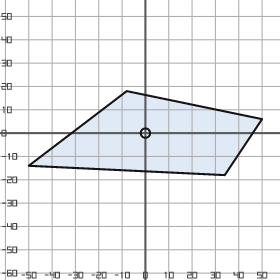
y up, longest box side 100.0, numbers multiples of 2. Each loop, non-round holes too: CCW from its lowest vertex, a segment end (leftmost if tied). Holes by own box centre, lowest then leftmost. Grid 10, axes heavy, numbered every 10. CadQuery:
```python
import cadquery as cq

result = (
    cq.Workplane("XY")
    .moveTo(34.0, -18.0)
    .lineTo(50.0, 6.0)
    .lineTo(-8.0, 18.0)
    .lineTo(-50.0, -14.0)
    .close()
    .moveTo(0.0, 0.0)
    .circle(2.0)
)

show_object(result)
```